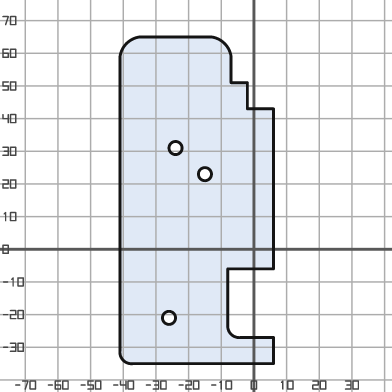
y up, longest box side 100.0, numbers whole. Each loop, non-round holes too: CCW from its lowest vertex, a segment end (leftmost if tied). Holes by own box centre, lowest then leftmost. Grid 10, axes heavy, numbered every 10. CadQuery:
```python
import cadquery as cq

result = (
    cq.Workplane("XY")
    .moveTo(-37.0, -35.0)
    .lineTo(6.0, -35.0)
    .lineTo(6.0, -27.0)
    .lineTo(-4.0, -27.0)
    .threePointArc((-7.0, -26.0), (-8.0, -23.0))
    .lineTo(-8.0, -6.0)
    .lineTo(6.0, -6.0)
    .lineTo(6.0, 43.0)
    .lineTo(-2.0, 43.0)
    .lineTo(-2.0, 51.0)
    .lineTo(-7.0, 51.0)
    .lineTo(-7.0, 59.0)
    .threePointArc((-9.0, 63.0), (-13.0, 65.0))
    .lineTo(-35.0, 65.0)
    .threePointArc((-39.0, 63.0), (-41.0, 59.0))
    .lineTo(-41.0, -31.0)
    .threePointArc((-40.0, -34.0), (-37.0, -35.0))
    .close()
    .moveTo(-26.0, -21.0)
    .circle(2.0)
    .moveTo(-15.0, 23.0)
    .circle(2.0)
    .moveTo(-24.0, 31.0)
    .circle(2.0)
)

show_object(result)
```